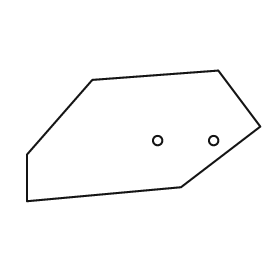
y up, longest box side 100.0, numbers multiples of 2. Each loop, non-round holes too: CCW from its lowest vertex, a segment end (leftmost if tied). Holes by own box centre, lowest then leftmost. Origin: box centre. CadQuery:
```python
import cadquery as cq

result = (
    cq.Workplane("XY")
    .moveTo(-50.0, -28.0)
    .lineTo(16.0, -22.0)
    .lineTo(50.0, 4.0)
    .lineTo(32.0, 28.0)
    .lineTo(-22.0, 24.0)
    .lineTo(-50.0, -8.0)
    .close()
    .moveTo(6.0, -2.0)
    .circle(2.0)
    .moveTo(30.0, -2.0)
    .circle(2.0)
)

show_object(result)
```